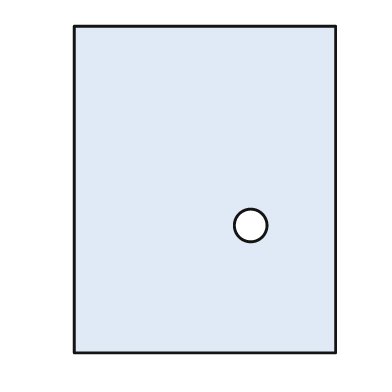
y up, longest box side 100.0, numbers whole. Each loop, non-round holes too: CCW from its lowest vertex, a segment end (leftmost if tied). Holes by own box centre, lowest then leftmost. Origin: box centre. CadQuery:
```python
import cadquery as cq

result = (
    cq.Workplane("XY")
    .moveTo(-40.0, -50.0)
    .lineTo(40.0, -50.0)
    .lineTo(40.0, 50.0)
    .lineTo(-40.0, 50.0)
    .close()
    .moveTo(14.0, -11.0)
    .circle(5.0)
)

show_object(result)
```